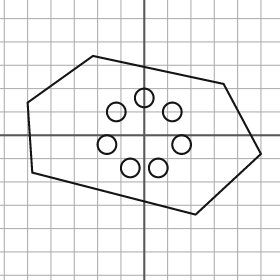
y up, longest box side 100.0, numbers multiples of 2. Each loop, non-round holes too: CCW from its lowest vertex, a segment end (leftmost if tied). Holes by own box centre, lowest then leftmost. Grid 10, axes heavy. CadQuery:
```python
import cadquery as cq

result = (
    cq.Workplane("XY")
    .moveTo(22.0, -34.0)
    .lineTo(50.0, -8.0)
    .lineTo(34.0, 22.0)
    .lineTo(-22.0, 34.0)
    .lineTo(-50.0, 14.0)
    .lineTo(-48.0, -16.0)
    .close()
    .moveTo(-6.0, -14.0)
    .circle(4.0)
    .moveTo(6.0, -14.0)
    .circle(4.0)
    .moveTo(-16.0, -4.0)
    .circle(4.0)
    .moveTo(16.0, -4.0)
    .circle(4.0)
    .moveTo(-12.0, 10.0)
    .circle(4.0)
    .moveTo(12.0, 10.0)
    .circle(4.0)
    .moveTo(0.0, 16.0)
    .circle(4.0)
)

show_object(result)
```